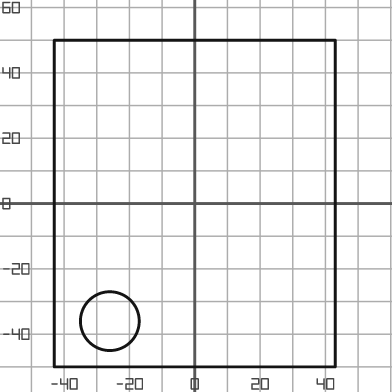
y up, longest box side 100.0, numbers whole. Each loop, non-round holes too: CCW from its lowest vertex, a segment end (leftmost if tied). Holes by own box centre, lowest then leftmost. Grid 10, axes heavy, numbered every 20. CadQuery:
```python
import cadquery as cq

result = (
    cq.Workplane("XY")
    .moveTo(-43.0, -50.0)
    .lineTo(43.0, -50.0)
    .lineTo(43.0, 50.0)
    .lineTo(-43.0, 50.0)
    .close()
    .moveTo(-26.0, -36.0)
    .circle(9.0)
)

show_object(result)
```